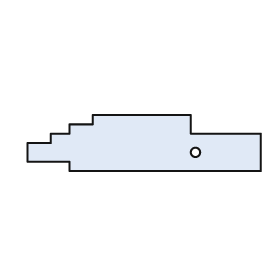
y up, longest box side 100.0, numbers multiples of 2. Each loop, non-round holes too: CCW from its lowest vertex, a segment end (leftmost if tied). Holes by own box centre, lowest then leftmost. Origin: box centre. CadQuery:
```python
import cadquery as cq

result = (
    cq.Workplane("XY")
    .moveTo(-32.0, -12.0)
    .lineTo(50.0, -12.0)
    .lineTo(50.0, 4.0)
    .lineTo(20.0, 4.0)
    .lineTo(20.0, 12.0)
    .lineTo(-22.0, 12.0)
    .lineTo(-22.0, 8.0)
    .lineTo(-32.0, 8.0)
    .lineTo(-32.0, 4.0)
    .lineTo(-40.0, 4.0)
    .lineTo(-40.0, 0.0)
    .lineTo(-50.0, 0.0)
    .lineTo(-50.0, -8.0)
    .lineTo(-32.0, -8.0)
    .close()
    .moveTo(22.0, -4.0)
    .circle(2.0)
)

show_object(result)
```